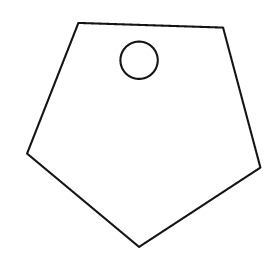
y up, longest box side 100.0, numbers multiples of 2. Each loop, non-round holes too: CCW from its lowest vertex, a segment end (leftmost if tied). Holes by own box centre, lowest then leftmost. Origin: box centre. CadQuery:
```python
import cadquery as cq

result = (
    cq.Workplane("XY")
    .moveTo(-2.0, -48.0)
    .lineTo(50.0, -14.0)
    .lineTo(34.0, 46.0)
    .lineTo(-28.0, 48.0)
    .lineTo(-50.0, -8.0)
    .close()
    .moveTo(-2.0, 32.0)
    .circle(8.0)
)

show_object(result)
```